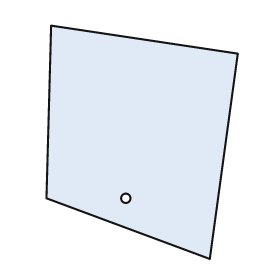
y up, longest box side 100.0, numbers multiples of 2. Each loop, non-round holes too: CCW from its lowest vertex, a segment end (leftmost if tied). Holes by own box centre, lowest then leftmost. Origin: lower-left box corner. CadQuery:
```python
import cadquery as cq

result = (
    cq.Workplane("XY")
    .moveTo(70.0, 0.0)
    .lineTo(82.0, 88.0)
    .lineTo(2.0, 100.0)
    .lineTo(0.0, 26.0)
    .close()
    .moveTo(34.0, 26.0)
    .circle(2.0)
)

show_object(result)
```